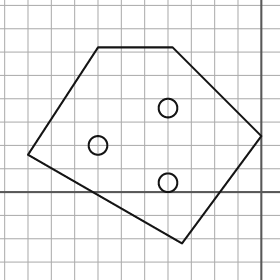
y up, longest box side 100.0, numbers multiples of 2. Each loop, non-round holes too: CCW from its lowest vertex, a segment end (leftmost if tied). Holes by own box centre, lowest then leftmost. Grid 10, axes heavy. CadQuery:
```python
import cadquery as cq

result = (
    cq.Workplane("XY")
    .moveTo(-34.0, -22.0)
    .lineTo(0.0, 24.0)
    .lineTo(-38.0, 62.0)
    .lineTo(-70.0, 62.0)
    .lineTo(-100.0, 16.0)
    .close()
    .moveTo(-40.0, 4.0)
    .circle(4.0)
    .moveTo(-70.0, 20.0)
    .circle(4.0)
    .moveTo(-40.0, 36.0)
    .circle(4.0)
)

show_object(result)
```